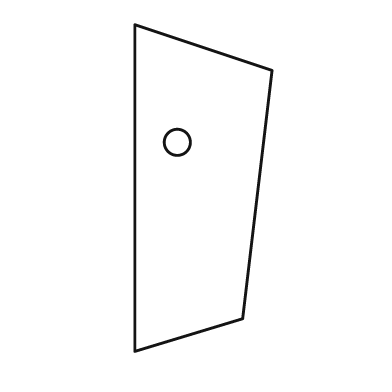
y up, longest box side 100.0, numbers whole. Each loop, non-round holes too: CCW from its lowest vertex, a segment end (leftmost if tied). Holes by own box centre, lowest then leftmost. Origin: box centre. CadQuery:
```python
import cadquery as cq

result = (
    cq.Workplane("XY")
    .moveTo(-21.0, -50.0)
    .lineTo(12.0, -40.0)
    .lineTo(21.0, 36.0)
    .lineTo(-21.0, 50.0)
    .close()
    .moveTo(-8.0, 14.0)
    .circle(4.0)
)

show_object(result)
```